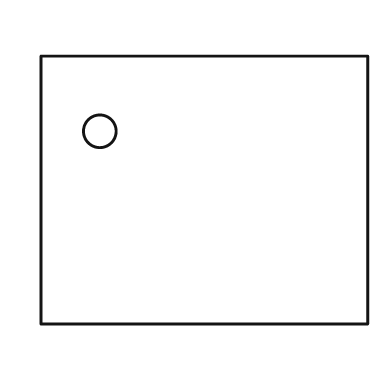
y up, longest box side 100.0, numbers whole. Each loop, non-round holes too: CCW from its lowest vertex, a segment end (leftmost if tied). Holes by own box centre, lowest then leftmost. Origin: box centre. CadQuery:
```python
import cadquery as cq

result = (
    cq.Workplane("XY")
    .moveTo(-50.0, -41.0)
    .lineTo(50.0, -41.0)
    .lineTo(50.0, 41.0)
    .lineTo(-50.0, 41.0)
    .close()
    .moveTo(-32.0, 18.0)
    .circle(5.0)
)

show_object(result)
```